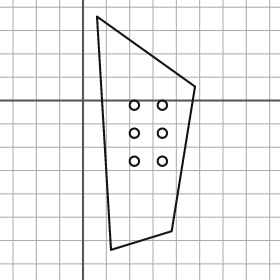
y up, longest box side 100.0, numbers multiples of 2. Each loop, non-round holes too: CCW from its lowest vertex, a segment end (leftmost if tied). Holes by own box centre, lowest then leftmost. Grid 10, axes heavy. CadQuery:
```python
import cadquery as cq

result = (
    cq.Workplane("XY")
    .moveTo(12.0, -64.0)
    .lineTo(38.0, -56.0)
    .lineTo(48.0, 6.0)
    .lineTo(6.0, 36.0)
    .close()
    .moveTo(22.0, -26.0)
    .circle(2.0)
    .moveTo(34.0, -26.0)
    .circle(2.0)
    .moveTo(22.0, -14.0)
    .circle(2.0)
    .moveTo(34.0, -14.0)
    .circle(2.0)
    .moveTo(22.0, -2.0)
    .circle(2.0)
    .moveTo(34.0, -2.0)
    .circle(2.0)
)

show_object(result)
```